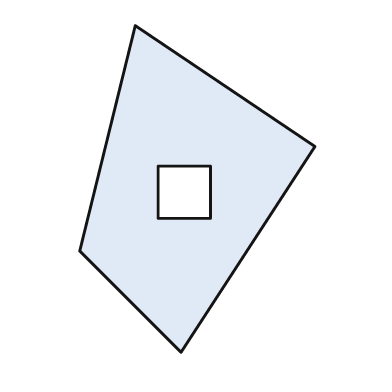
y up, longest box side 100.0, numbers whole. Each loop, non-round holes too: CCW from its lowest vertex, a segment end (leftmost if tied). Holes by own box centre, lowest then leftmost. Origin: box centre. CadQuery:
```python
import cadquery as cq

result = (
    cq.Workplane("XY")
    .moveTo(-5.0, -50.0)
    .lineTo(36.0, 13.0)
    .lineTo(-19.0, 50.0)
    .lineTo(-36.0, -19.0)
    .close()
    .moveTo(-12.0, -9.0)
    .lineTo(4.0, -9.0)
    .lineTo(4.0, 7.0)
    .lineTo(-12.0, 7.0)
    .close()
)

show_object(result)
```